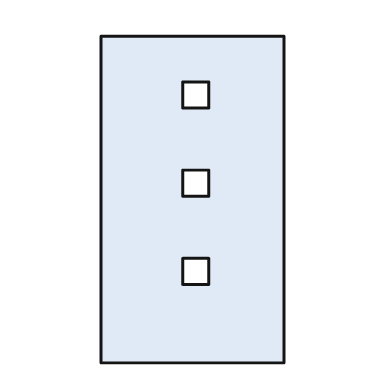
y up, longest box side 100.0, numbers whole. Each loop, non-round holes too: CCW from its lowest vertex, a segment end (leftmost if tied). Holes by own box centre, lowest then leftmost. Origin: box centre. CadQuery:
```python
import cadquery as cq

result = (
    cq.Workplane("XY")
    .moveTo(-28.0, -50.0)
    .lineTo(28.0, -50.0)
    .lineTo(28.0, 50.0)
    .lineTo(-28.0, 50.0)
    .close()
    .moveTo(-3.0, -26.0)
    .lineTo(5.0, -26.0)
    .lineTo(5.0, -18.0)
    .lineTo(-3.0, -18.0)
    .close()
    .moveTo(-3.0, 1.0)
    .lineTo(5.0, 1.0)
    .lineTo(5.0, 9.0)
    .lineTo(-3.0, 9.0)
    .close()
    .moveTo(-3.0, 28.0)
    .lineTo(5.0, 28.0)
    .lineTo(5.0, 36.0)
    .lineTo(-3.0, 36.0)
    .close()
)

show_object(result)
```